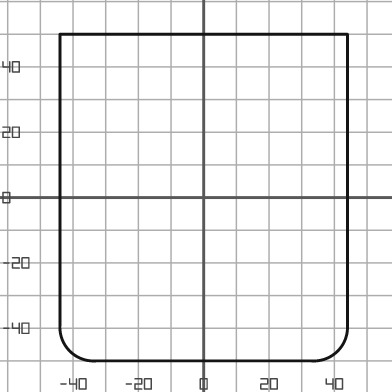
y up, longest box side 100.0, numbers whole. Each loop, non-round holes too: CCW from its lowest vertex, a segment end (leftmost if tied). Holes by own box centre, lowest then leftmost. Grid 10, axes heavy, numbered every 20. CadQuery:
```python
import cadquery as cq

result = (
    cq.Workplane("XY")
    .moveTo(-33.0, -50.0)
    .lineTo(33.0, -50.0)
    .threePointArc((41.0, -47.0), (44.0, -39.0))
    .lineTo(44.0, 50.0)
    .lineTo(-44.0, 50.0)
    .lineTo(-44.0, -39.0)
    .threePointArc((-41.0, -47.0), (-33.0, -50.0))
    .close()
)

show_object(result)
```